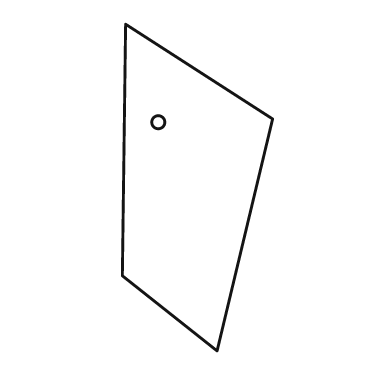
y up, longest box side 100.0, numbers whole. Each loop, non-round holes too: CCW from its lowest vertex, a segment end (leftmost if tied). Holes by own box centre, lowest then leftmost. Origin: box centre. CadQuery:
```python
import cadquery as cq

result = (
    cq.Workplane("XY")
    .moveTo(6.0, -50.0)
    .lineTo(23.0, 21.0)
    .lineTo(-22.0, 50.0)
    .lineTo(-23.0, -27.0)
    .close()
    .moveTo(-12.0, 20.0)
    .circle(2.0)
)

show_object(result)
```